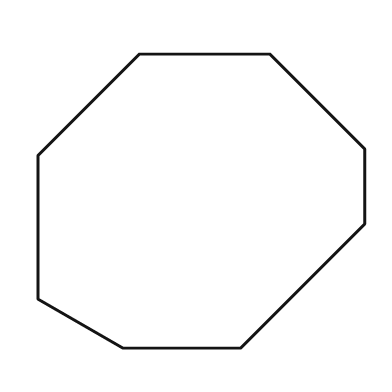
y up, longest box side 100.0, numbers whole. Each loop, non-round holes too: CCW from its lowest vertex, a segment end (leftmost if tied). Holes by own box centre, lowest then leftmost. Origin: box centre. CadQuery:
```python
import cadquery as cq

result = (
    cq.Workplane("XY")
    .moveTo(-24.0, -45.0)
    .lineTo(12.0, -45.0)
    .lineTo(50.0, -7.0)
    .lineTo(50.0, 16.0)
    .lineTo(21.0, 45.0)
    .lineTo(-19.0, 45.0)
    .lineTo(-50.0, 14.0)
    .lineTo(-50.0, -30.0)
    .close()
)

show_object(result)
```